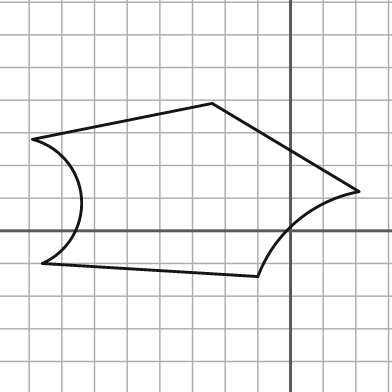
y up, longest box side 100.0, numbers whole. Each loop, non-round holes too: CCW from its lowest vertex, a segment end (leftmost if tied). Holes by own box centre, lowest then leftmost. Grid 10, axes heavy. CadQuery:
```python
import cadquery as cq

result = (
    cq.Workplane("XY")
    .moveTo(-10.0, -14.0)
    .threePointArc((2.0, 3.0), (21.0, 12.0))
    .lineTo(-24.0, 39.0)
    .lineTo(-79.0, 28.0)
    .threePointArc((-64.0, 10.0), (-76.0, -10.0))
    .close()
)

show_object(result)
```